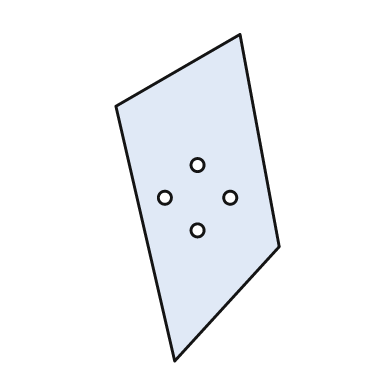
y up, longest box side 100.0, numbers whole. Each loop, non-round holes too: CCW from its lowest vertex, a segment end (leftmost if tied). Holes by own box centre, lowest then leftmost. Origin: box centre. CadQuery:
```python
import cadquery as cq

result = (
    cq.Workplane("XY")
    .moveTo(-7.0, -50.0)
    .lineTo(25.0, -15.0)
    .lineTo(13.0, 50.0)
    .lineTo(-25.0, 28.0)
    .close()
    .moveTo(0.0, -10.0)
    .circle(2.0)
    .moveTo(-10.0, 0.0)
    .circle(2.0)
    .moveTo(10.0, 0.0)
    .circle(2.0)
    .moveTo(0.0, 10.0)
    .circle(2.0)
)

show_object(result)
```